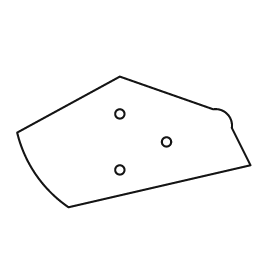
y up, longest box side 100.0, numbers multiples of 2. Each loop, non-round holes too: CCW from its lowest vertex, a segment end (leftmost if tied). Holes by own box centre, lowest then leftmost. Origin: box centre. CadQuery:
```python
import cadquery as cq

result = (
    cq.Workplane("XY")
    .moveTo(-28.0, -28.0)
    .lineTo(50.0, -10.0)
    .lineTo(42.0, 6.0)
    .threePointArc((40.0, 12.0), (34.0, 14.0))
    .lineTo(-6.0, 28.0)
    .lineTo(-50.0, 4.0)
    .threePointArc((-42.0, -14.0), (-28.0, -28.0))
    .close()
    .moveTo(-6.0, -12.0)
    .circle(2.0)
    .moveTo(14.0, 0.0)
    .circle(2.0)
    .moveTo(-6.0, 12.0)
    .circle(2.0)
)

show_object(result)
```